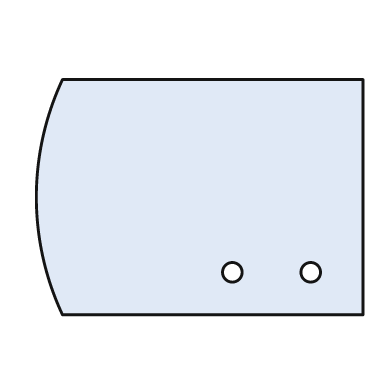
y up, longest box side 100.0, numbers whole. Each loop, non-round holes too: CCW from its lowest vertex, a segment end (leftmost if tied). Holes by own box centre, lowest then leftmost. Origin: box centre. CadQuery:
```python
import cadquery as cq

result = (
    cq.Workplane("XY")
    .moveTo(-42.0, -36.0)
    .lineTo(50.0, -36.0)
    .lineTo(50.0, 36.0)
    .lineTo(-42.0, 36.0)
    .threePointArc((-50.0, 0.0), (-42.0, -36.0))
    .close()
    .moveTo(10.0, -23.0)
    .circle(3.0)
    .moveTo(34.0, -23.0)
    .circle(3.0)
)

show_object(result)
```